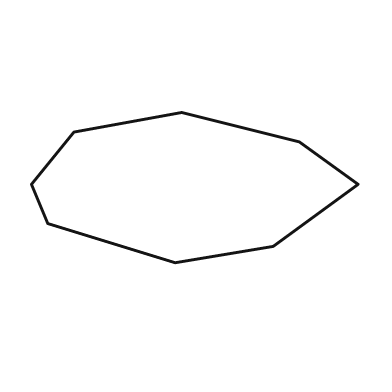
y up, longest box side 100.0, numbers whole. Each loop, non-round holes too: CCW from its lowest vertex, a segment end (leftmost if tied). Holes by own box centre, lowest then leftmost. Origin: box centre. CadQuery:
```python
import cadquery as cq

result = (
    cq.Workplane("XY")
    .moveTo(-6.0, -23.0)
    .lineTo(24.0, -18.0)
    .lineTo(50.0, 1.0)
    .lineTo(32.0, 14.0)
    .lineTo(-4.0, 23.0)
    .lineTo(-37.0, 17.0)
    .lineTo(-50.0, 1.0)
    .lineTo(-45.0, -11.0)
    .close()
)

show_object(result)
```